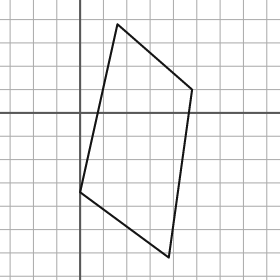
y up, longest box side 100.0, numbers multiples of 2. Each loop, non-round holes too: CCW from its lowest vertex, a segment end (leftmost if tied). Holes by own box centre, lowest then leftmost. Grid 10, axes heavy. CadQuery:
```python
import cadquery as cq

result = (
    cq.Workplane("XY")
    .moveTo(38.0, -62.0)
    .lineTo(48.0, 10.0)
    .lineTo(16.0, 38.0)
    .lineTo(0.0, -34.0)
    .close()
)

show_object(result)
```